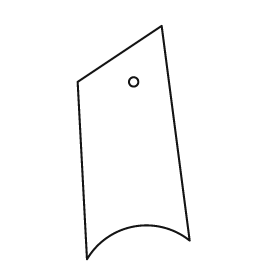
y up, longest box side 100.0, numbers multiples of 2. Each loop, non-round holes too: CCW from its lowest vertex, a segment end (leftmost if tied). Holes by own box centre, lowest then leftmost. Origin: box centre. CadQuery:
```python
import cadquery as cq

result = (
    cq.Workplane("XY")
    .moveTo(-20.0, -50.0)
    .threePointArc((0.0, -36.0), (24.0, -42.0))
    .lineTo(12.0, 50.0)
    .lineTo(-24.0, 26.0)
    .close()
    .moveTo(0.0, 26.0)
    .circle(2.0)
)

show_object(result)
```